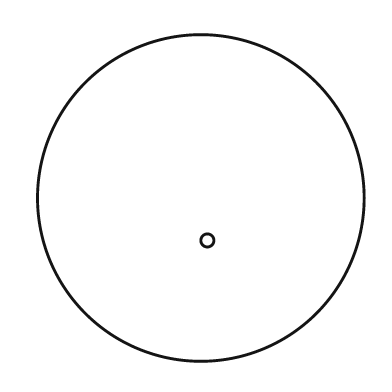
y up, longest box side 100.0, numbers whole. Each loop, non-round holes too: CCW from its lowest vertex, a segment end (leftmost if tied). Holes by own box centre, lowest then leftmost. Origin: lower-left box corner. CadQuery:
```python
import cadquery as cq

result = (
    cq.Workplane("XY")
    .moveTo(50.0, 50.0)
    .circle(50.0)
    .moveTo(52.0, 37.0)
    .circle(2.0)
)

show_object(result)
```